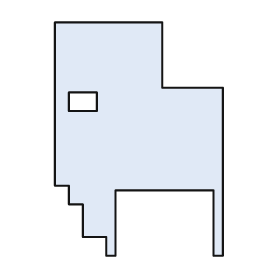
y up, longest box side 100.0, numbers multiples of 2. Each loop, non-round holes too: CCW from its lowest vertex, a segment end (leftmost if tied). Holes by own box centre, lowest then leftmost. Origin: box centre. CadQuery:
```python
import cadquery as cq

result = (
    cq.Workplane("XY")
    .moveTo(-14.0, -50.0)
    .lineTo(-10.0, -50.0)
    .lineTo(-10.0, -22.0)
    .lineTo(32.0, -22.0)
    .lineTo(32.0, -50.0)
    .lineTo(36.0, -50.0)
    .lineTo(36.0, 22.0)
    .lineTo(10.0, 22.0)
    .lineTo(10.0, 50.0)
    .lineTo(-36.0, 50.0)
    .lineTo(-36.0, -20.0)
    .lineTo(-30.0, -20.0)
    .lineTo(-30.0, -28.0)
    .lineTo(-24.0, -28.0)
    .lineTo(-24.0, -42.0)
    .lineTo(-14.0, -42.0)
    .close()
    .moveTo(-30.0, 12.0)
    .lineTo(-18.0, 12.0)
    .lineTo(-18.0, 20.0)
    .lineTo(-30.0, 20.0)
    .close()
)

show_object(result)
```